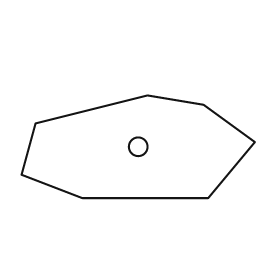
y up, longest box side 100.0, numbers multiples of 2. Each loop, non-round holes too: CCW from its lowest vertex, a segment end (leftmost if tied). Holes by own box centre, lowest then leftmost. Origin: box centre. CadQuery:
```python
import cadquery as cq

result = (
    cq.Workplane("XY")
    .moveTo(-24.0, -22.0)
    .lineTo(30.0, -22.0)
    .lineTo(50.0, 2.0)
    .lineTo(28.0, 18.0)
    .lineTo(4.0, 22.0)
    .lineTo(-44.0, 10.0)
    .lineTo(-50.0, -12.0)
    .close()
    .moveTo(0.0, 0.0)
    .circle(4.0)
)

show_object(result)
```